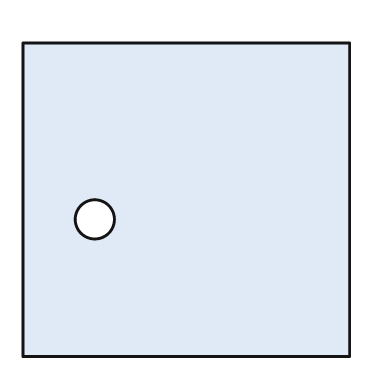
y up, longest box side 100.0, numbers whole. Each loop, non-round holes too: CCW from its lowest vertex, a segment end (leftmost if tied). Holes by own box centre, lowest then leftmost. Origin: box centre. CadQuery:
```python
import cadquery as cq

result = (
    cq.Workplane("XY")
    .moveTo(-50.0, -48.0)
    .lineTo(50.0, -48.0)
    .lineTo(50.0, 48.0)
    .lineTo(-50.0, 48.0)
    .close()
    .moveTo(-28.0, -6.0)
    .circle(6.0)
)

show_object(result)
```